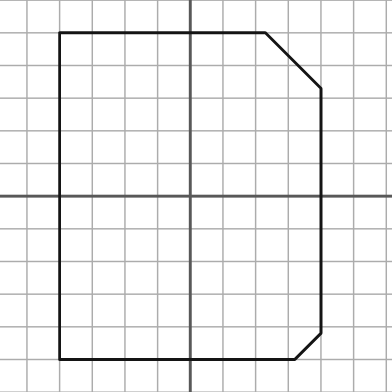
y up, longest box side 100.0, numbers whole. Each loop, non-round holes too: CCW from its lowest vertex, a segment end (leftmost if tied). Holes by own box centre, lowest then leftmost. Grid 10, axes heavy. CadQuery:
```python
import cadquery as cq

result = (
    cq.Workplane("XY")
    .moveTo(-40.0, -50.0)
    .lineTo(32.0, -50.0)
    .lineTo(40.0, -42.0)
    .lineTo(40.0, 33.0)
    .lineTo(23.0, 50.0)
    .lineTo(-40.0, 50.0)
    .close()
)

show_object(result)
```